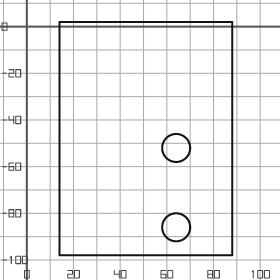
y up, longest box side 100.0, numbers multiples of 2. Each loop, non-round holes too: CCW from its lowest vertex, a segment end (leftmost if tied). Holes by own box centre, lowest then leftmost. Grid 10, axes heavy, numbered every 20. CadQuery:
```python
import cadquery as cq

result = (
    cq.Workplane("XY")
    .moveTo(14.0, -98.0)
    .lineTo(88.0, -98.0)
    .lineTo(88.0, 2.0)
    .lineTo(14.0, 2.0)
    .close()
    .moveTo(64.0, -86.0)
    .circle(6.0)
    .moveTo(64.0, -52.0)
    .circle(6.0)
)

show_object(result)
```